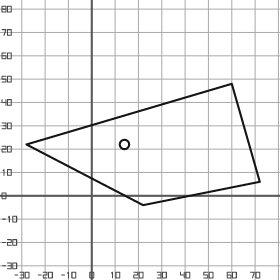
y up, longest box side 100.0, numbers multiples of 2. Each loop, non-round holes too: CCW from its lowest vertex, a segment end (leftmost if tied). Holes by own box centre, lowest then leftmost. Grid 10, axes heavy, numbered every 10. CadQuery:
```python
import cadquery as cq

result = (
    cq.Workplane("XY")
    .moveTo(22.0, -4.0)
    .lineTo(72.0, 6.0)
    .lineTo(60.0, 48.0)
    .lineTo(-28.0, 22.0)
    .close()
    .moveTo(14.0, 22.0)
    .circle(2.0)
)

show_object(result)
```